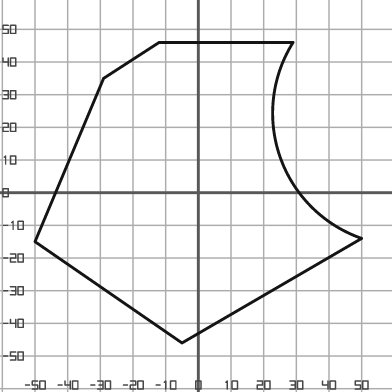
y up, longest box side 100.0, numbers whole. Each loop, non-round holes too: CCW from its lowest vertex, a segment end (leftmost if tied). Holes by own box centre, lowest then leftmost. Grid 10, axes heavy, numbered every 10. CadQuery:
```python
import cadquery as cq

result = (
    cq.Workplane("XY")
    .moveTo(-5.0, -46.0)
    .lineTo(50.0, -14.0)
    .threePointArc((25.0, 11.0), (29.0, 46.0))
    .lineTo(-12.0, 46.0)
    .lineTo(-29.0, 35.0)
    .lineTo(-50.0, -15.0)
    .close()
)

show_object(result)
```